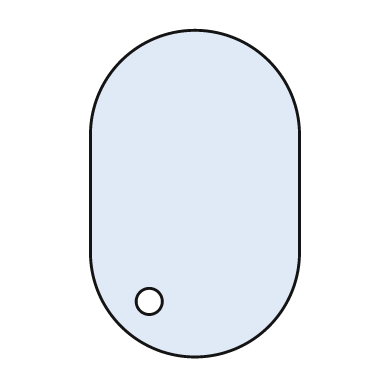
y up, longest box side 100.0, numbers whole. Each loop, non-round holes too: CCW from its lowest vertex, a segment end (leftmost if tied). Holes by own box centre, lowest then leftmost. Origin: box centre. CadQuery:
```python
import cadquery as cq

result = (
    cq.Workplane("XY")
    .moveTo(-32.0, -18.0)
    .threePointArc((0.0, -50.0), (32.0, -18.0))
    .lineTo(32.0, 18.0)
    .threePointArc((0.0, 50.0), (-32.0, 18.0))
    .close()
    .moveTo(-14.0, -33.0)
    .circle(4.0)
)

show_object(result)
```